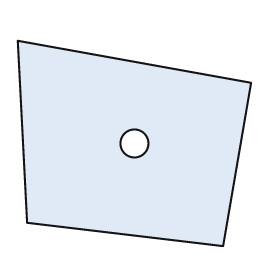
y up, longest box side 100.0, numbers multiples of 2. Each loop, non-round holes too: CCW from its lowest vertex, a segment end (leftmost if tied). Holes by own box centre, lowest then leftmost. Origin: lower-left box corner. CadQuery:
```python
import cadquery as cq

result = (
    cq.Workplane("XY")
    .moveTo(88.0, 0.0)
    .lineTo(100.0, 70.0)
    .lineTo(0.0, 88.0)
    .lineTo(4.0, 10.0)
    .close()
    .moveTo(50.0, 44.0)
    .circle(6.0)
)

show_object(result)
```